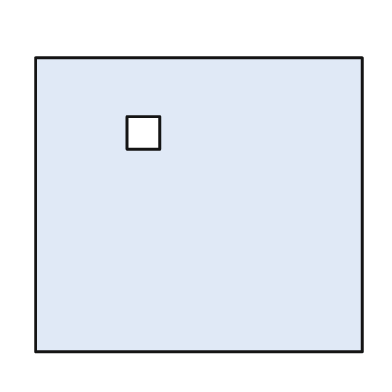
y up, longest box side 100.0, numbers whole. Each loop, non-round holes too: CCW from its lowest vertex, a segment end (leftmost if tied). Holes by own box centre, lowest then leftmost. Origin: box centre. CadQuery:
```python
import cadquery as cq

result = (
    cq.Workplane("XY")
    .moveTo(-50.0, -45.0)
    .lineTo(50.0, -45.0)
    .lineTo(50.0, 45.0)
    .lineTo(-50.0, 45.0)
    .close()
    .moveTo(-22.0, 17.0)
    .lineTo(-12.0, 17.0)
    .lineTo(-12.0, 27.0)
    .lineTo(-22.0, 27.0)
    .close()
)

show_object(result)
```